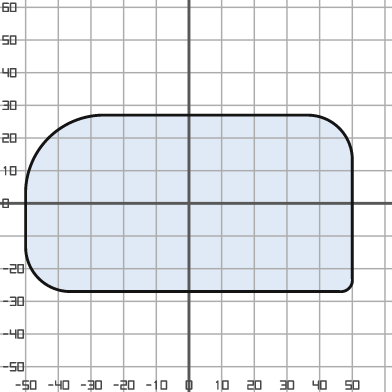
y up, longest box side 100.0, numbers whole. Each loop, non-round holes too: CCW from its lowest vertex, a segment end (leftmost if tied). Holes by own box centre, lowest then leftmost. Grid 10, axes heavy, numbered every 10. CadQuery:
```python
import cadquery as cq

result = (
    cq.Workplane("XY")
    .moveTo(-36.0, -27.0)
    .lineTo(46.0, -27.0)
    .threePointArc((49.0, -26.0), (50.0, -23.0))
    .lineTo(50.0, 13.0)
    .threePointArc((46.0, 23.0), (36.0, 27.0))
    .lineTo(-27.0, 27.0)
    .threePointArc((-43.0, 20.0), (-50.0, 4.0))
    .lineTo(-50.0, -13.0)
    .threePointArc((-46.0, -23.0), (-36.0, -27.0))
    .close()
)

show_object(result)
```